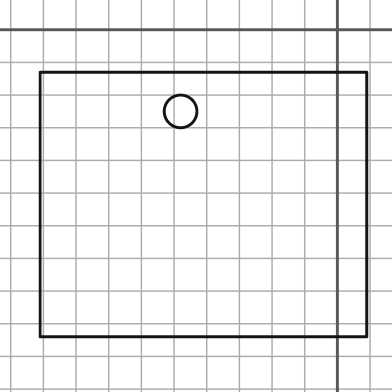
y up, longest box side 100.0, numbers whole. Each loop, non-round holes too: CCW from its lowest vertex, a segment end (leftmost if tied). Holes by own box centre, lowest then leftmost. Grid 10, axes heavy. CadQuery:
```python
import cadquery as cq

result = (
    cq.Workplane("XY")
    .moveTo(-91.0, -94.0)
    .lineTo(9.0, -94.0)
    .lineTo(9.0, -13.0)
    .lineTo(-91.0, -13.0)
    .close()
    .moveTo(-48.0, -25.0)
    .circle(5.0)
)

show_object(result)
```